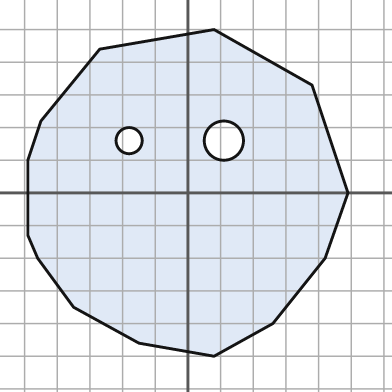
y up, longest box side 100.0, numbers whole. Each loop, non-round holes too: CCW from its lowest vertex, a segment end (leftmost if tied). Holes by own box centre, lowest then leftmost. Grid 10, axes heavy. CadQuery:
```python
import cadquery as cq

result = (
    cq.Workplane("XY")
    .moveTo(8.0, -50.0)
    .lineTo(26.0, -40.0)
    .lineTo(42.0, -20.0)
    .lineTo(49.0, 0.0)
    .lineTo(38.0, 33.0)
    .lineTo(8.0, 50.0)
    .lineTo(-27.0, 44.0)
    .lineTo(-45.0, 22.0)
    .lineTo(-49.0, 10.0)
    .lineTo(-49.0, -13.0)
    .lineTo(-46.0, -20.0)
    .lineTo(-35.0, -35.0)
    .lineTo(-15.0, -46.0)
    .close()
    .moveTo(-18.0, 16.0)
    .circle(4.0)
    .moveTo(11.0, 16.0)
    .circle(6.0)
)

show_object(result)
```